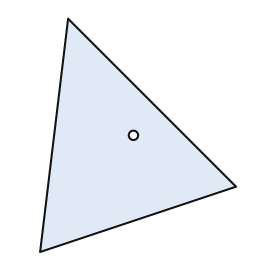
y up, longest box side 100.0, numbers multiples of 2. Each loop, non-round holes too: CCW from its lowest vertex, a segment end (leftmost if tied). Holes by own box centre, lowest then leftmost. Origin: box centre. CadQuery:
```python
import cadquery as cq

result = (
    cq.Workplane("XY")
    .moveTo(-42.0, -50.0)
    .lineTo(42.0, -22.0)
    .lineTo(-30.0, 50.0)
    .close()
    .moveTo(-2.0, 0.0)
    .circle(2.0)
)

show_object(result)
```